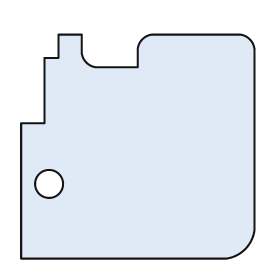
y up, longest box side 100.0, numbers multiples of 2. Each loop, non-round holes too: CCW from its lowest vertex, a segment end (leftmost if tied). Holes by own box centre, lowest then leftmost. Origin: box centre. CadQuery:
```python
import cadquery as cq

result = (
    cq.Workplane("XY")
    .moveTo(-50.0, -48.0)
    .lineTo(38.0, -48.0)
    .threePointArc((46.0, -44.0), (50.0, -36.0))
    .lineTo(50.0, 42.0)
    .threePointArc((48.0, 46.0), (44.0, 48.0))
    .lineTo(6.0, 48.0)
    .threePointArc((2.0, 46.0), (0.0, 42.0))
    .lineTo(0.0, 34.0)
    .lineTo(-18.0, 34.0)
    .threePointArc((-22.0, 36.0), (-24.0, 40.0))
    .lineTo(-24.0, 48.0)
    .lineTo(-34.0, 48.0)
    .lineTo(-34.0, 38.0)
    .lineTo(-40.0, 38.0)
    .lineTo(-40.0, 10.0)
    .lineTo(-50.0, 10.0)
    .close()
    .moveTo(-38.0, -16.0)
    .circle(6.0)
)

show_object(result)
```